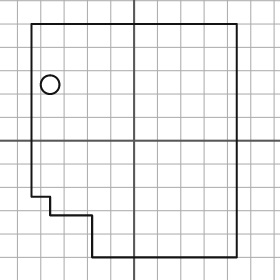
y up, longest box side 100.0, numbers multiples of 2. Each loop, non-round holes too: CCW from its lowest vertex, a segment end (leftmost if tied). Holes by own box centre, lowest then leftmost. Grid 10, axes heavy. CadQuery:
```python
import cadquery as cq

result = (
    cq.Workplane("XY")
    .moveTo(-18.0, -50.0)
    .lineTo(44.0, -50.0)
    .lineTo(44.0, 50.0)
    .lineTo(-44.0, 50.0)
    .lineTo(-44.0, -24.0)
    .lineTo(-36.0, -24.0)
    .lineTo(-36.0, -32.0)
    .lineTo(-18.0, -32.0)
    .close()
    .moveTo(-36.0, 24.0)
    .circle(4.0)
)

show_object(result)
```